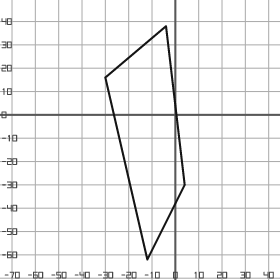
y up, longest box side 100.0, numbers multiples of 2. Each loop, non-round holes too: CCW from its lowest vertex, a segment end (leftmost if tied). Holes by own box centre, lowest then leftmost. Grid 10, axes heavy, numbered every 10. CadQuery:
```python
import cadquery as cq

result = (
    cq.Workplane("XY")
    .moveTo(-12.0, -62.0)
    .lineTo(4.0, -30.0)
    .lineTo(-4.0, 38.0)
    .lineTo(-30.0, 16.0)
    .close()
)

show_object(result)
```